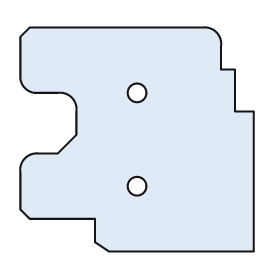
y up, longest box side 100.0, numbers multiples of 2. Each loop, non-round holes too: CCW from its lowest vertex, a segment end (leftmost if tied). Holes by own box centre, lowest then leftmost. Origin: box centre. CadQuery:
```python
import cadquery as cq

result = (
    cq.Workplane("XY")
    .moveTo(-12.0, -48.0)
    .lineTo(50.0, -48.0)
    .lineTo(50.0, 12.0)
    .lineTo(42.0, 12.0)
    .lineTo(42.0, 30.0)
    .lineTo(36.0, 30.0)
    .lineTo(36.0, 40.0)
    .threePointArc((34.0, 46.0), (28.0, 48.0))
    .lineTo(-46.0, 48.0)
    .lineTo(-50.0, 44.0)
    .lineTo(-50.0, 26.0)
    .threePointArc((-48.0, 22.0), (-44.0, 20.0))
    .lineTo(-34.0, 20.0)
    .threePointArc((-28.0, 18.0), (-26.0, 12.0))
    .lineTo(-26.0, 2.0)
    .lineTo(-34.0, -6.0)
    .lineTo(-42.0, -6.0)
    .threePointArc((-48.0, -8.0), (-50.0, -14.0))
    .lineTo(-50.0, -30.0)
    .lineTo(-46.0, -34.0)
    .lineTo(-18.0, -34.0)
    .lineTo(-18.0, -44.0)
    .close()
    .moveTo(0.0, -20.0)
    .circle(4.0)
    .moveTo(0.0, 20.0)
    .circle(4.0)
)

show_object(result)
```